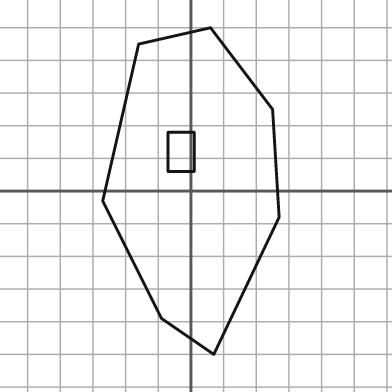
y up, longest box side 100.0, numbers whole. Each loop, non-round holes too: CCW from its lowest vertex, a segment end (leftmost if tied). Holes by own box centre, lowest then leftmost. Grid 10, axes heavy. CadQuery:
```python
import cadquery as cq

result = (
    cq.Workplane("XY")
    .moveTo(7.0, -50.0)
    .lineTo(27.0, -8.0)
    .lineTo(25.0, 25.0)
    .lineTo(6.0, 50.0)
    .lineTo(-16.0, 45.0)
    .lineTo(-27.0, -3.0)
    .lineTo(-9.0, -39.0)
    .close()
    .moveTo(-7.0, 6.0)
    .lineTo(1.0, 6.0)
    .lineTo(1.0, 18.0)
    .lineTo(-7.0, 18.0)
    .close()
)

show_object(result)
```